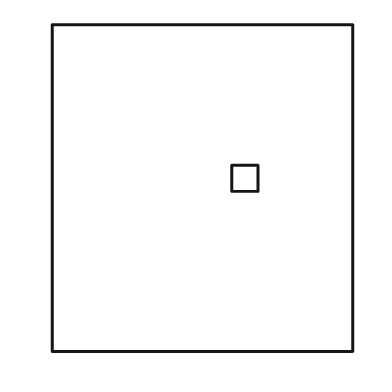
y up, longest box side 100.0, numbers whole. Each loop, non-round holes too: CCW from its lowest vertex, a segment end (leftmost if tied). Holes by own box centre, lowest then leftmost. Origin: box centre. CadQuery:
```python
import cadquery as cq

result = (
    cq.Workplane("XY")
    .moveTo(-46.0, -50.0)
    .lineTo(46.0, -50.0)
    .lineTo(46.0, 50.0)
    .lineTo(-46.0, 50.0)
    .close()
    .moveTo(9.0, -1.0)
    .lineTo(17.0, -1.0)
    .lineTo(17.0, 7.0)
    .lineTo(9.0, 7.0)
    .close()
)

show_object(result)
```